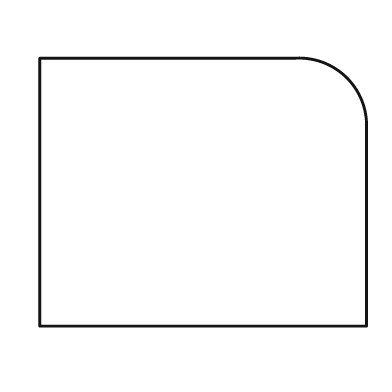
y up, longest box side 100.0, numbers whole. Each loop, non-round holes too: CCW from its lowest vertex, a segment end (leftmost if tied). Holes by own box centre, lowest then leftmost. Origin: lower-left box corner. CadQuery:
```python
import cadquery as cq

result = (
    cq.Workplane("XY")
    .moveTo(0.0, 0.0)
    .lineTo(100.0, 0.0)
    .lineTo(100.0, 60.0)
    .threePointArc((94.0, 76.0), (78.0, 82.0))
    .lineTo(0.0, 82.0)
    .close()
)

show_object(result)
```